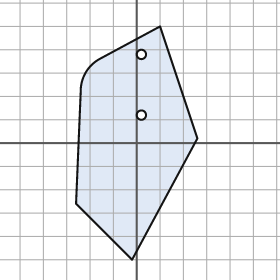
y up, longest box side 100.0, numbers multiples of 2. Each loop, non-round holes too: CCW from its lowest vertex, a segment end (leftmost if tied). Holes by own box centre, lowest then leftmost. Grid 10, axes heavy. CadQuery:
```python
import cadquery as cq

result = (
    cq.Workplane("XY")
    .moveTo(-2.0, -50.0)
    .lineTo(26.0, 2.0)
    .lineTo(10.0, 50.0)
    .lineTo(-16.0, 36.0)
    .threePointArc((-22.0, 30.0), (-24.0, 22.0))
    .lineTo(-26.0, -26.0)
    .close()
    .moveTo(2.0, 12.0)
    .circle(2.0)
    .moveTo(2.0, 38.0)
    .circle(2.0)
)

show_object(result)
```